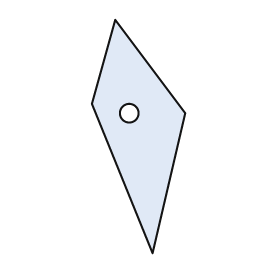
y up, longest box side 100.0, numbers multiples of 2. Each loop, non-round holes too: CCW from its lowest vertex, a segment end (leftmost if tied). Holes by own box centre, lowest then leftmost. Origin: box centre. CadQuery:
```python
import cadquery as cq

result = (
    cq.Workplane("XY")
    .moveTo(6.0, -50.0)
    .lineTo(20.0, 10.0)
    .lineTo(-10.0, 50.0)
    .lineTo(-20.0, 14.0)
    .close()
    .moveTo(-4.0, 10.0)
    .circle(4.0)
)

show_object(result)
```